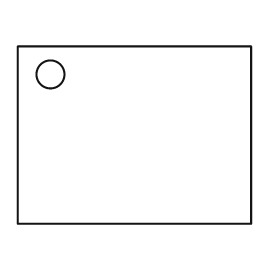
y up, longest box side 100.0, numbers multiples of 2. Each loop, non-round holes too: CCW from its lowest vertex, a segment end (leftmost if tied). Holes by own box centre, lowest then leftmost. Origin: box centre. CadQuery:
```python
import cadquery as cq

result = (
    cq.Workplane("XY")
    .moveTo(-50.0, -38.0)
    .lineTo(50.0, -38.0)
    .lineTo(50.0, 38.0)
    .lineTo(-50.0, 38.0)
    .close()
    .moveTo(-36.0, 26.0)
    .circle(6.0)
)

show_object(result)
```